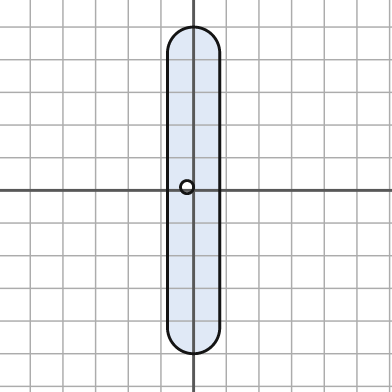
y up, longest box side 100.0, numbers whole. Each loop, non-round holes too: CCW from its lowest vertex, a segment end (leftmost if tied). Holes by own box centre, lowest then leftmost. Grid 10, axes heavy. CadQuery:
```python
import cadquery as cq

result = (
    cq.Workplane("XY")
    .moveTo(-8.0, -42.0)
    .threePointArc((0.0, -50.0), (8.0, -42.0))
    .lineTo(8.0, 42.0)
    .threePointArc((0.0, 50.0), (-8.0, 42.0))
    .close()
    .moveTo(-2.0, 1.0)
    .circle(2.0)
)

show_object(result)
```